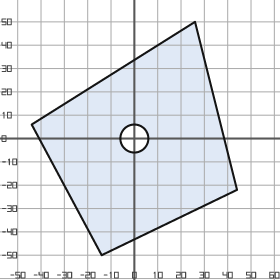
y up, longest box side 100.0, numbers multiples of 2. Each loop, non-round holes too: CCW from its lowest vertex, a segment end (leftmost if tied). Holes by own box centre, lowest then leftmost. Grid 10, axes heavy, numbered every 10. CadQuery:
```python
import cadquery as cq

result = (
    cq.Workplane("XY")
    .moveTo(-14.0, -50.0)
    .lineTo(44.0, -22.0)
    .lineTo(26.0, 50.0)
    .lineTo(-44.0, 6.0)
    .close()
    .moveTo(0.0, 0.0)
    .circle(6.0)
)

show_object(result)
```